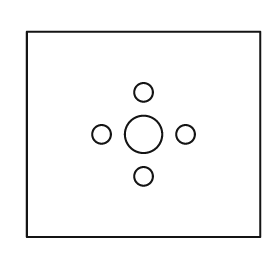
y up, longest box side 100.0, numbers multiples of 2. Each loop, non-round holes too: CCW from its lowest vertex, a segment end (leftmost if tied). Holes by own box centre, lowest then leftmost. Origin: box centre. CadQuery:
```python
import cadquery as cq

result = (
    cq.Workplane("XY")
    .moveTo(-50.0, -44.0)
    .lineTo(50.0, -44.0)
    .lineTo(50.0, 44.0)
    .lineTo(-50.0, 44.0)
    .close()
    .moveTo(0.0, -18.0)
    .circle(4.0)
    .moveTo(-18.0, 0.0)
    .circle(4.0)
    .moveTo(0.0, 0.0)
    .circle(8.0)
    .moveTo(18.0, 0.0)
    .circle(4.0)
    .moveTo(0.0, 18.0)
    .circle(4.0)
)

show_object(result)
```